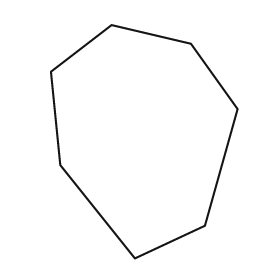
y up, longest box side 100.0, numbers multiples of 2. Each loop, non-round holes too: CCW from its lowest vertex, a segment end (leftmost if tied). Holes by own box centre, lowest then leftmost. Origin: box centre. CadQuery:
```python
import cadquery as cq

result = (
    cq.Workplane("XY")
    .moveTo(-4.0, -50.0)
    .lineTo(26.0, -36.0)
    .lineTo(40.0, 14.0)
    .lineTo(20.0, 42.0)
    .lineTo(-14.0, 50.0)
    .lineTo(-40.0, 30.0)
    .lineTo(-36.0, -10.0)
    .close()
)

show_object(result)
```